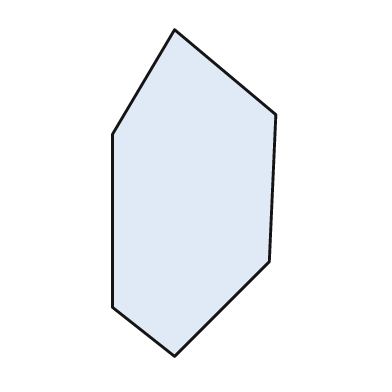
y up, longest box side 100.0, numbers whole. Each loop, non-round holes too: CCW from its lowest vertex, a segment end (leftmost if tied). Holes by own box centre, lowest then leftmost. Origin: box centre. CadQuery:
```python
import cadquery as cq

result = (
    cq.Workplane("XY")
    .moveTo(-6.0, -50.0)
    .lineTo(23.0, -21.0)
    .lineTo(25.0, 24.0)
    .lineTo(-6.0, 50.0)
    .lineTo(-25.0, 18.0)
    .lineTo(-25.0, -35.0)
    .close()
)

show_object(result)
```